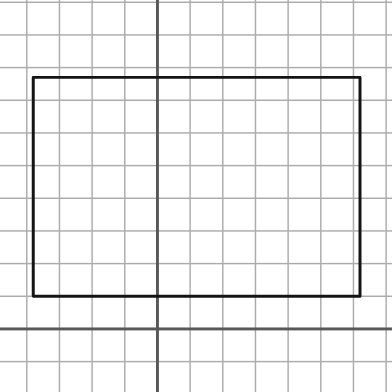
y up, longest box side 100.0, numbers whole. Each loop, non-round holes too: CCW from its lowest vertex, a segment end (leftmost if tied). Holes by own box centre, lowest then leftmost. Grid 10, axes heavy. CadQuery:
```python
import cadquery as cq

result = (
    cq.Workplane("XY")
    .moveTo(-38.0, 10.0)
    .lineTo(62.0, 10.0)
    .lineTo(62.0, 77.0)
    .lineTo(-38.0, 77.0)
    .close()
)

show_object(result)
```